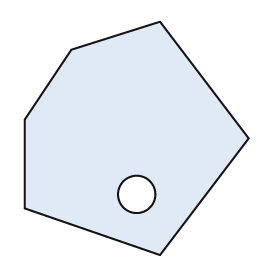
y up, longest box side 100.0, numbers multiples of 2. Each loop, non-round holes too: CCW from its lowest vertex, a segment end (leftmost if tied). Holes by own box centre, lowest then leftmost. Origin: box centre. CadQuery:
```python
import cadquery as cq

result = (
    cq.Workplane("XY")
    .moveTo(10.0, -50.0)
    .lineTo(48.0, 0.0)
    .lineTo(10.0, 50.0)
    .lineTo(-28.0, 38.0)
    .lineTo(-48.0, 8.0)
    .lineTo(-48.0, -30.0)
    .close()
    .moveTo(0.0, -24.0)
    .circle(8.0)
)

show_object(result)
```